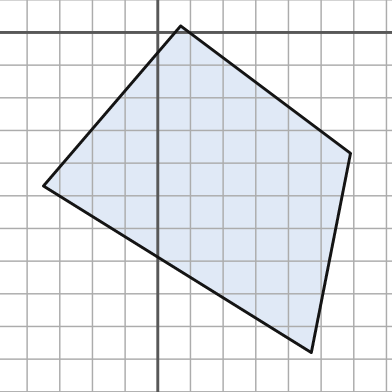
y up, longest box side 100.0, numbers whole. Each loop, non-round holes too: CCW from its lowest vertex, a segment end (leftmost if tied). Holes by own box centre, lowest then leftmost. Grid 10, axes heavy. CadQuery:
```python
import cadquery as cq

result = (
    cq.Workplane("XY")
    .moveTo(47.0, -98.0)
    .lineTo(59.0, -37.0)
    .lineTo(7.0, 2.0)
    .lineTo(-35.0, -47.0)
    .close()
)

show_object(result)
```